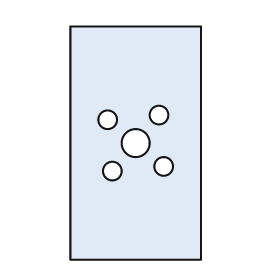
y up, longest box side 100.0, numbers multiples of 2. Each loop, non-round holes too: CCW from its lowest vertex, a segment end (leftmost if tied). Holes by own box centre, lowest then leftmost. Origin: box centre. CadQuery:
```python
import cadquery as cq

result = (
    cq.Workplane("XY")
    .moveTo(-28.0, -50.0)
    .lineTo(28.0, -50.0)
    .lineTo(28.0, 50.0)
    .lineTo(-28.0, 50.0)
    .close()
    .moveTo(-10.0, -12.0)
    .circle(4.0)
    .moveTo(12.0, -10.0)
    .circle(4.0)
    .moveTo(0.0, 0.0)
    .circle(6.0)
    .moveTo(-12.0, 10.0)
    .circle(4.0)
    .moveTo(10.0, 12.0)
    .circle(4.0)
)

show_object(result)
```